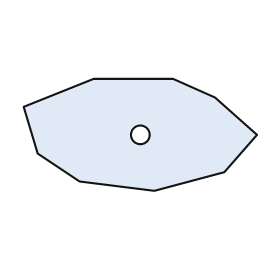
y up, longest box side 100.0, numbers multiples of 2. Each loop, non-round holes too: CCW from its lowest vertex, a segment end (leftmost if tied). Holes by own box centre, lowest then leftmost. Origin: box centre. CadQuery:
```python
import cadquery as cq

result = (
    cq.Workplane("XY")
    .moveTo(6.0, -24.0)
    .lineTo(36.0, -16.0)
    .lineTo(50.0, 0.0)
    .lineTo(32.0, 16.0)
    .lineTo(14.0, 24.0)
    .lineTo(-20.0, 24.0)
    .lineTo(-50.0, 12.0)
    .lineTo(-44.0, -8.0)
    .lineTo(-26.0, -20.0)
    .close()
    .moveTo(0.0, 0.0)
    .circle(4.0)
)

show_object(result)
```